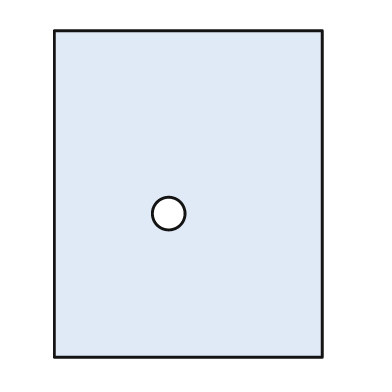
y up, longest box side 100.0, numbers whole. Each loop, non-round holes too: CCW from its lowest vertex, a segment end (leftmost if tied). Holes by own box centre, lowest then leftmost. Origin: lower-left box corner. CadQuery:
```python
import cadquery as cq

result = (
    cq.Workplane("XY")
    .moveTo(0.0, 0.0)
    .lineTo(82.0, 0.0)
    .lineTo(82.0, 100.0)
    .lineTo(0.0, 100.0)
    .close()
    .moveTo(35.0, 44.0)
    .circle(5.0)
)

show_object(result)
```